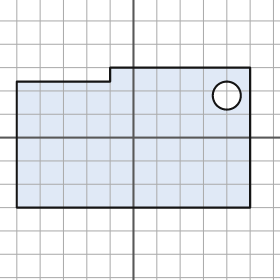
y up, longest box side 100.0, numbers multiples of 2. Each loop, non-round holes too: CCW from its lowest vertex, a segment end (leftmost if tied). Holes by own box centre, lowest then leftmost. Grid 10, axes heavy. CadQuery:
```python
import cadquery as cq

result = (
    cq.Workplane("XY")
    .moveTo(-50.0, -30.0)
    .lineTo(50.0, -30.0)
    .lineTo(50.0, 30.0)
    .lineTo(-10.0, 30.0)
    .lineTo(-10.0, 24.0)
    .lineTo(-50.0, 24.0)
    .close()
    .moveTo(40.0, 18.0)
    .circle(6.0)
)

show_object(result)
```